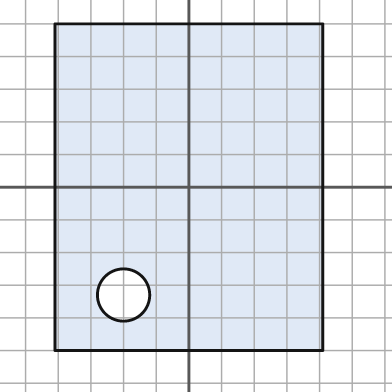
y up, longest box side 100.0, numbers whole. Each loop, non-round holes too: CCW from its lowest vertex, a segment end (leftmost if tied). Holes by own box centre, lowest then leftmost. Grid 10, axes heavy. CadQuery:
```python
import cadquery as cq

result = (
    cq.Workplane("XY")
    .moveTo(-41.0, -50.0)
    .lineTo(41.0, -50.0)
    .lineTo(41.0, 50.0)
    .lineTo(-41.0, 50.0)
    .close()
    .moveTo(-20.0, -33.0)
    .circle(8.0)
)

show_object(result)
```